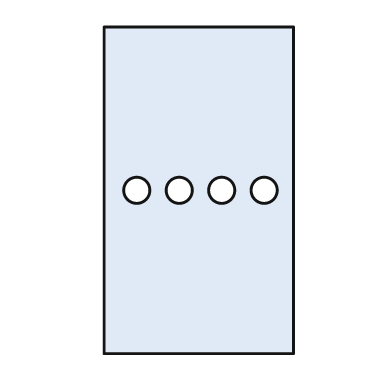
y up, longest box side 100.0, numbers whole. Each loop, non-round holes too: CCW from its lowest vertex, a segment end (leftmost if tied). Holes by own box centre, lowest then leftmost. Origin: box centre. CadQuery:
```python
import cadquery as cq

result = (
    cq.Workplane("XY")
    .moveTo(-29.0, -50.0)
    .lineTo(29.0, -50.0)
    .lineTo(29.0, 50.0)
    .lineTo(-29.0, 50.0)
    .close()
    .moveTo(-19.0, 0.0)
    .circle(4.0)
    .moveTo(-6.0, 0.0)
    .circle(4.0)
    .moveTo(7.0, 0.0)
    .circle(4.0)
    .moveTo(20.0, 0.0)
    .circle(4.0)
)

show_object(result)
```